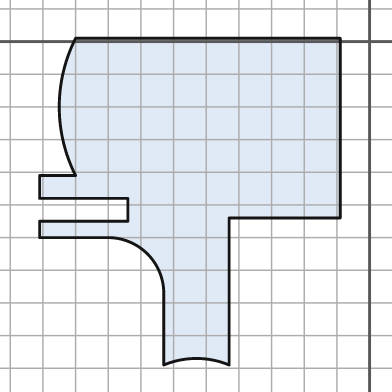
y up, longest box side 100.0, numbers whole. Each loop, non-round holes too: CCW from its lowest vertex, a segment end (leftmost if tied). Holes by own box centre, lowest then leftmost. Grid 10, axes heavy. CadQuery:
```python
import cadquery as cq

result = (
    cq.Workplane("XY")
    .moveTo(-63.0, -99.0)
    .threePointArc((-53.0, -97.0), (-43.0, -99.0))
    .lineTo(-43.0, -54.0)
    .lineTo(-9.0, -54.0)
    .lineTo(-9.0, 1.0)
    .lineTo(-90.0, 1.0)
    .threePointArc((-95.0, -20.0), (-90.0, -41.0))
    .lineTo(-101.0, -41.0)
    .lineTo(-101.0, -48.0)
    .lineTo(-74.0, -48.0)
    .lineTo(-74.0, -55.0)
    .lineTo(-101.0, -55.0)
    .lineTo(-101.0, -60.0)
    .lineTo(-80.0, -60.0)
    .threePointArc((-68.0, -65.0), (-63.0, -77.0))
    .close()
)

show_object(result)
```